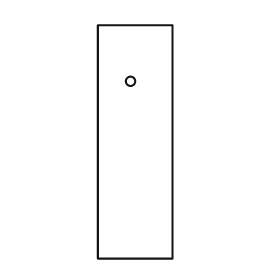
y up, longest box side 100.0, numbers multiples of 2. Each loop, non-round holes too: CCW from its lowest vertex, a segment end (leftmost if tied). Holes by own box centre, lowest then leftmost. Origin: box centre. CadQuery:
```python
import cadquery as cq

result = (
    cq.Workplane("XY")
    .moveTo(-16.0, -50.0)
    .lineTo(16.0, -50.0)
    .lineTo(16.0, 50.0)
    .lineTo(-16.0, 50.0)
    .close()
    .moveTo(-2.0, 26.0)
    .circle(2.0)
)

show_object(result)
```